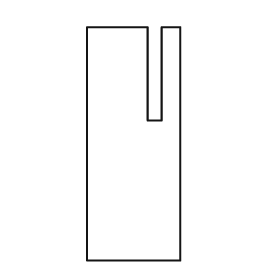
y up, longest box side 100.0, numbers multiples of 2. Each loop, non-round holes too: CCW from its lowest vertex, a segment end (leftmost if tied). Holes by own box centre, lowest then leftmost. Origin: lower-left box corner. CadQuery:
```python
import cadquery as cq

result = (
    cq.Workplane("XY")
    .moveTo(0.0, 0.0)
    .lineTo(40.0, 0.0)
    .lineTo(40.0, 100.0)
    .lineTo(32.0, 100.0)
    .lineTo(32.0, 60.0)
    .lineTo(26.0, 60.0)
    .lineTo(26.0, 100.0)
    .lineTo(0.0, 100.0)
    .close()
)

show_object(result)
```